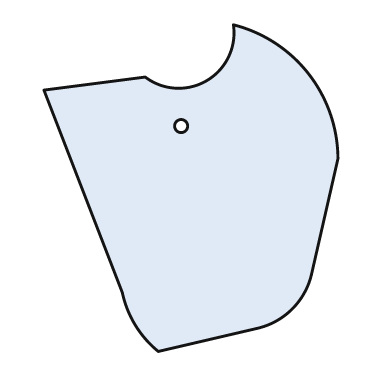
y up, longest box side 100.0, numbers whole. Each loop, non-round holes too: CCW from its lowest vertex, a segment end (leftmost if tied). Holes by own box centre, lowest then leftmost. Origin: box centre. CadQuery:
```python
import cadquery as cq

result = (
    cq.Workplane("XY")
    .moveTo(-10.0, -50.0)
    .lineTo(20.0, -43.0)
    .threePointArc((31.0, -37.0), (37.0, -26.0))
    .lineTo(45.0, 9.0)
    .threePointArc((36.0, 35.0), (13.0, 50.0))
    .threePointArc((5.0, 33.0), (-14.0, 34.0))
    .lineTo(-45.0, 30.0)
    .lineTo(-21.0, -32.0)
    .threePointArc((-17.0, -42.0), (-10.0, -50.0))
    .close()
    .moveTo(-3.0, 19.0)
    .circle(2.0)
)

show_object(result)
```